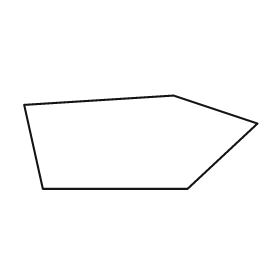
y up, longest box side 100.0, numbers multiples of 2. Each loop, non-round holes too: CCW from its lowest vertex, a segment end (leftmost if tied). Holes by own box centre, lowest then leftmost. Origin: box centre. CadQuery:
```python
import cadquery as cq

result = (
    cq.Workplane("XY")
    .moveTo(-42.0, -20.0)
    .lineTo(20.0, -20.0)
    .lineTo(50.0, 8.0)
    .lineTo(14.0, 20.0)
    .lineTo(-50.0, 16.0)
    .close()
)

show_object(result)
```